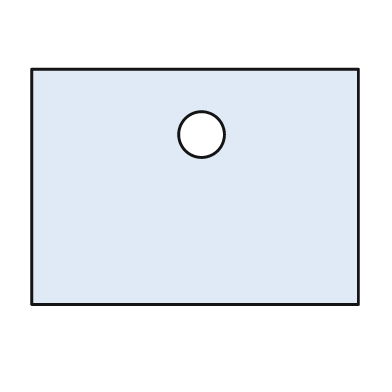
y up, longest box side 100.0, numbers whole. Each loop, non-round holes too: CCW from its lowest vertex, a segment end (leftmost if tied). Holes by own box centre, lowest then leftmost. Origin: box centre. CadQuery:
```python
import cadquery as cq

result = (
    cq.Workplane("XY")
    .moveTo(-50.0, -36.0)
    .lineTo(50.0, -36.0)
    .lineTo(50.0, 36.0)
    .lineTo(-50.0, 36.0)
    .close()
    .moveTo(2.0, 16.0)
    .circle(7.0)
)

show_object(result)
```